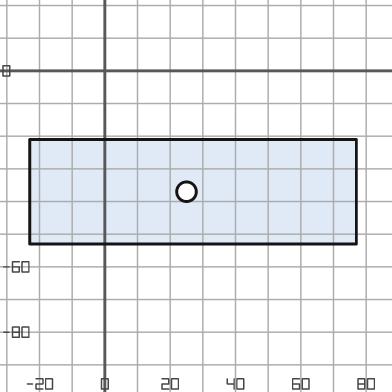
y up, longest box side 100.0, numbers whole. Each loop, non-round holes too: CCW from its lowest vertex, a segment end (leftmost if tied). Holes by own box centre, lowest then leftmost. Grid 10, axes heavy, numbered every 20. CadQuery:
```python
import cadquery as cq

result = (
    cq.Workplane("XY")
    .moveTo(-23.0, -53.0)
    .lineTo(77.0, -53.0)
    .lineTo(77.0, -21.0)
    .lineTo(-23.0, -21.0)
    .close()
    .moveTo(25.0, -37.0)
    .circle(3.0)
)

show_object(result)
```